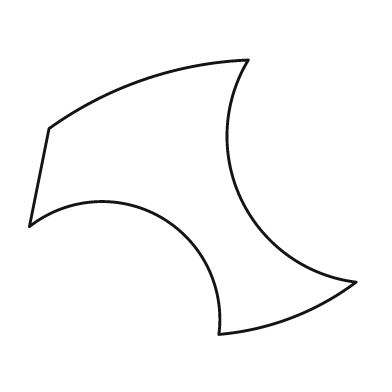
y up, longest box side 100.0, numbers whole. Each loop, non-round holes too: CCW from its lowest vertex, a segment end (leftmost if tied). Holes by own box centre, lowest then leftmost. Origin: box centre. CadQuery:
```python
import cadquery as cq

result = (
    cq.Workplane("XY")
    .moveTo(8.0, -42.0)
    .threePointArc((30.0, -37.0), (50.0, -26.0))
    .threePointArc((15.0, -1.0), (17.0, 42.0))
    .threePointArc((-15.0, 36.0), (-44.0, 21.0))
    .lineTo(-50.0, -9.0)
    .threePointArc((-10.0, -6.0), (8.0, -42.0))
    .close()
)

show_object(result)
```